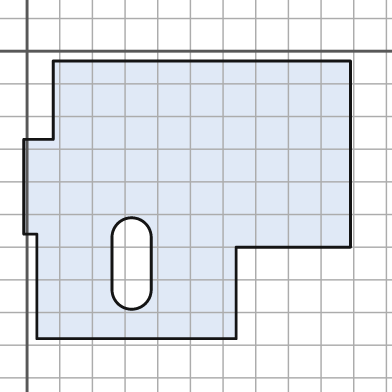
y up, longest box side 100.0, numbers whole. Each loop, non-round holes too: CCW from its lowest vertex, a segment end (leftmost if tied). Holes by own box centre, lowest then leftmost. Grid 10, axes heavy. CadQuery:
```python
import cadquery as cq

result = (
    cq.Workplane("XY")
    .moveTo(3.0, -88.0)
    .lineTo(64.0, -88.0)
    .lineTo(64.0, -60.0)
    .lineTo(99.0, -60.0)
    .lineTo(99.0, -3.0)
    .lineTo(8.0, -3.0)
    .lineTo(8.0, -27.0)
    .lineTo(-1.0, -27.0)
    .lineTo(-1.0, -56.0)
    .lineTo(3.0, -56.0)
    .close()
    .moveTo(26.0, -73.0)
    .threePointArc((32.0, -79.0), (38.0, -73.0))
    .lineTo(38.0, -57.0)
    .threePointArc((32.0, -51.0), (26.0, -57.0))
    .close()
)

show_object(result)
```